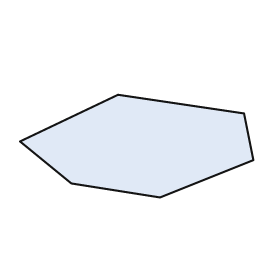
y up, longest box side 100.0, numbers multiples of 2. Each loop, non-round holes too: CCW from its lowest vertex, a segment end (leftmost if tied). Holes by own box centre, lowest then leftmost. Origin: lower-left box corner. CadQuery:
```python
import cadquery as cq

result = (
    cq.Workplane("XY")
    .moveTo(60.0, 0.0)
    .lineTo(100.0, 16.0)
    .lineTo(96.0, 36.0)
    .lineTo(42.0, 44.0)
    .lineTo(0.0, 24.0)
    .lineTo(22.0, 6.0)
    .close()
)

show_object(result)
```